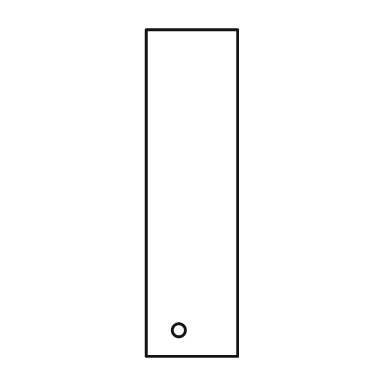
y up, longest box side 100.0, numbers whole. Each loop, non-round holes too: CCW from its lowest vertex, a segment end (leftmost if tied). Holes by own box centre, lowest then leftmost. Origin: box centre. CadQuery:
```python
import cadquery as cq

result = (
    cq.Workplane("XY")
    .moveTo(-14.0, -50.0)
    .lineTo(14.0, -50.0)
    .lineTo(14.0, 50.0)
    .lineTo(-14.0, 50.0)
    .close()
    .moveTo(-4.0, -42.0)
    .circle(2.0)
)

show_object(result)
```